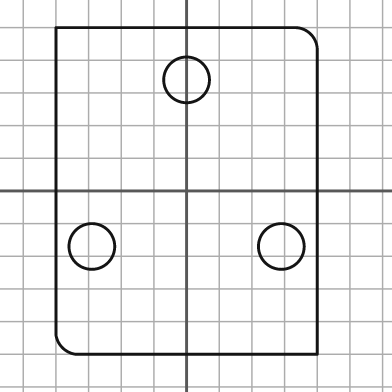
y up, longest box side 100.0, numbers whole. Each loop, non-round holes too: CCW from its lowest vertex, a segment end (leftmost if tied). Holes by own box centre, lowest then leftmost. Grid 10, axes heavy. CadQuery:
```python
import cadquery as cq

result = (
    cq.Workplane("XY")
    .moveTo(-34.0, -50.0)
    .lineTo(40.0, -50.0)
    .lineTo(40.0, 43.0)
    .threePointArc((38.0, 48.0), (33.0, 50.0))
    .lineTo(-40.0, 50.0)
    .lineTo(-40.0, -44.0)
    .threePointArc((-38.0, -48.0), (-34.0, -50.0))
    .close()
    .moveTo(-29.0, -17.0)
    .circle(7.0)
    .moveTo(29.0, -17.0)
    .circle(7.0)
    .moveTo(0.0, 34.0)
    .circle(7.0)
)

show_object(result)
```